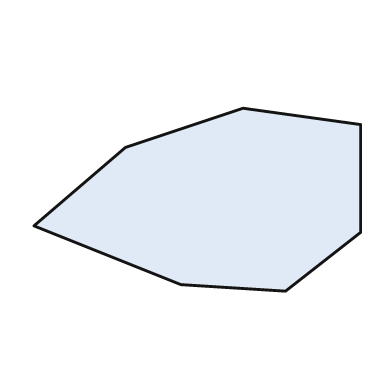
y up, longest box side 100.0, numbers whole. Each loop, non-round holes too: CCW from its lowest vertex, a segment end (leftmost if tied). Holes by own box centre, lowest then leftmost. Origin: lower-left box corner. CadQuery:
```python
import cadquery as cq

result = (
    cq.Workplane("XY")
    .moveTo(77.0, 0.0)
    .lineTo(100.0, 18.0)
    .lineTo(100.0, 51.0)
    .lineTo(64.0, 56.0)
    .lineTo(28.0, 44.0)
    .lineTo(0.0, 20.0)
    .lineTo(45.0, 2.0)
    .close()
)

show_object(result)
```